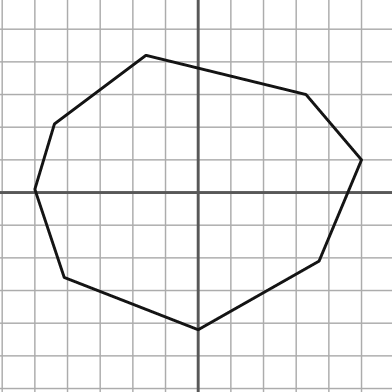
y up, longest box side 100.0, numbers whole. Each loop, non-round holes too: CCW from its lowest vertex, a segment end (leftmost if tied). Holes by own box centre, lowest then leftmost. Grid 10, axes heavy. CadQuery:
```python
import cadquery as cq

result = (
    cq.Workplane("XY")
    .moveTo(0.0, -42.0)
    .lineTo(37.0, -21.0)
    .lineTo(50.0, 10.0)
    .lineTo(33.0, 30.0)
    .lineTo(-16.0, 42.0)
    .lineTo(-44.0, 21.0)
    .lineTo(-50.0, 1.0)
    .lineTo(-41.0, -26.0)
    .close()
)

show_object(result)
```